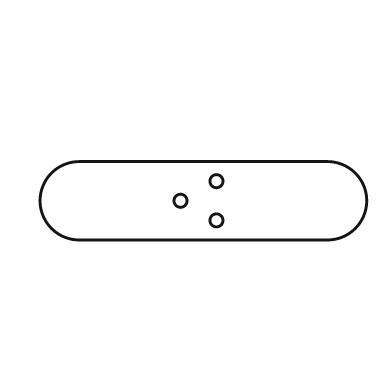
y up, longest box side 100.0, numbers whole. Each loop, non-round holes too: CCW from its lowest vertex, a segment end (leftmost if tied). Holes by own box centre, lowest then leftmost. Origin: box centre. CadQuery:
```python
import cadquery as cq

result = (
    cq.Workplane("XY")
    .moveTo(-38.0, -12.0)
    .lineTo(38.0, -12.0)
    .threePointArc((50.0, 0.0), (38.0, 12.0))
    .lineTo(-38.0, 12.0)
    .threePointArc((-50.0, 0.0), (-38.0, -12.0))
    .close()
    .moveTo(4.0, -6.0)
    .circle(2.0)
    .moveTo(-7.0, 0.0)
    .circle(2.0)
    .moveTo(4.0, 6.0)
    .circle(2.0)
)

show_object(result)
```